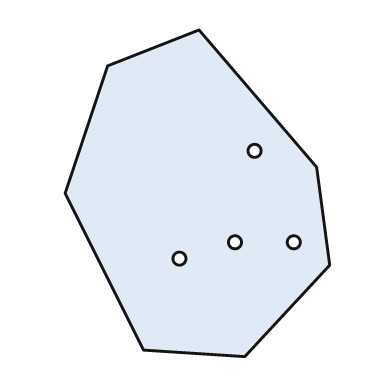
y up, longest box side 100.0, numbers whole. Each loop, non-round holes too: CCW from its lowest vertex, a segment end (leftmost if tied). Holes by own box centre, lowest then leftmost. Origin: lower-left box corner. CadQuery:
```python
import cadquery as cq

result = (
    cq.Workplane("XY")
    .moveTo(55.0, 0.0)
    .lineTo(81.0, 28.0)
    .lineTo(77.0, 58.0)
    .lineTo(41.0, 100.0)
    .lineTo(13.0, 89.0)
    .lineTo(0.0, 50.0)
    .lineTo(24.0, 2.0)
    .close()
    .moveTo(35.0, 30.0)
    .circle(2.0)
    .moveTo(52.0, 35.0)
    .circle(2.0)
    .moveTo(70.0, 35.0)
    .circle(2.0)
    .moveTo(58.0, 63.0)
    .circle(2.0)
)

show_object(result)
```